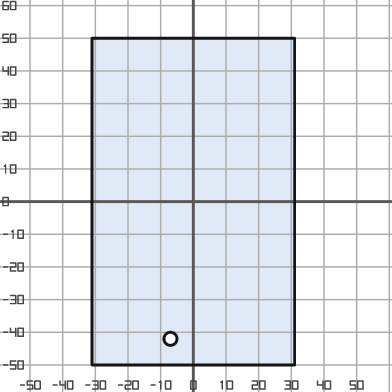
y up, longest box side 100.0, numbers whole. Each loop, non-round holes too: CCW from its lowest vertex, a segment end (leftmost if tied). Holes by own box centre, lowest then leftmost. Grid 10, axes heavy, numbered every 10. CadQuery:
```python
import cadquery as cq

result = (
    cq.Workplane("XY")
    .moveTo(-31.0, -50.0)
    .lineTo(31.0, -50.0)
    .lineTo(31.0, 50.0)
    .lineTo(-31.0, 50.0)
    .close()
    .moveTo(-7.0, -42.0)
    .circle(2.0)
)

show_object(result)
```